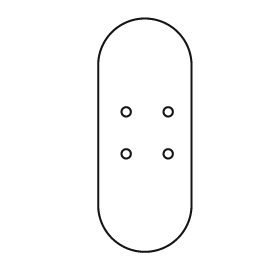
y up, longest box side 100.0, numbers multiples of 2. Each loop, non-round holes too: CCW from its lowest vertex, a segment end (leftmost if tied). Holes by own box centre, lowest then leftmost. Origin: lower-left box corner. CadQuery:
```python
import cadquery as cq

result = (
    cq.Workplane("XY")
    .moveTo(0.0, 20.0)
    .threePointArc((20.0, 0.0), (40.0, 20.0))
    .lineTo(40.0, 80.0)
    .threePointArc((20.0, 100.0), (0.0, 80.0))
    .close()
    .moveTo(12.0, 42.0)
    .circle(2.0)
    .moveTo(30.0, 42.0)
    .circle(2.0)
    .moveTo(12.0, 60.0)
    .circle(2.0)
    .moveTo(30.0, 60.0)
    .circle(2.0)
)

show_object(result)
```